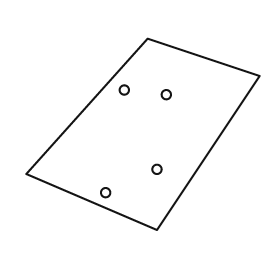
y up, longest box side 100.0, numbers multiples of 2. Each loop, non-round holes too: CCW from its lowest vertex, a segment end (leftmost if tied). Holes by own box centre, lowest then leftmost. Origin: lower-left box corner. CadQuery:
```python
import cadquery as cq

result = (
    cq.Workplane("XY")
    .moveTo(56.0, 0.0)
    .lineTo(100.0, 66.0)
    .lineTo(52.0, 82.0)
    .lineTo(0.0, 24.0)
    .close()
    .moveTo(34.0, 16.0)
    .circle(2.0)
    .moveTo(56.0, 26.0)
    .circle(2.0)
    .moveTo(60.0, 58.0)
    .circle(2.0)
    .moveTo(42.0, 60.0)
    .circle(2.0)
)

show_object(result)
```